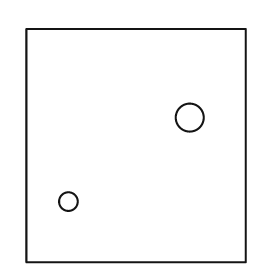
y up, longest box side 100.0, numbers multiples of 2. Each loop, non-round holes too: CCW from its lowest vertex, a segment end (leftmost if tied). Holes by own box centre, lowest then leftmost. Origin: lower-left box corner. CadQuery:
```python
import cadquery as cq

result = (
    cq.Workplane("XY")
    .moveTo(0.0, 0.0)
    .lineTo(94.0, 0.0)
    .lineTo(94.0, 100.0)
    .lineTo(0.0, 100.0)
    .close()
    .moveTo(18.0, 26.0)
    .circle(4.0)
    .moveTo(70.0, 62.0)
    .circle(6.0)
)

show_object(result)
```